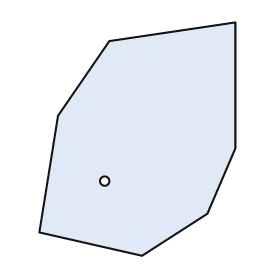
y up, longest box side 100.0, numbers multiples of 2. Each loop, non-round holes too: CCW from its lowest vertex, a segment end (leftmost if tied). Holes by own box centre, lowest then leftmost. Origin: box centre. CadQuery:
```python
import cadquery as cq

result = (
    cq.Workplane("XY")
    .moveTo(2.0, -50.0)
    .lineTo(30.0, -32.0)
    .lineTo(42.0, -4.0)
    .lineTo(42.0, 50.0)
    .lineTo(-12.0, 42.0)
    .lineTo(-34.0, 10.0)
    .lineTo(-42.0, -40.0)
    .close()
    .moveTo(-14.0, -18.0)
    .circle(2.0)
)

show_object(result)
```